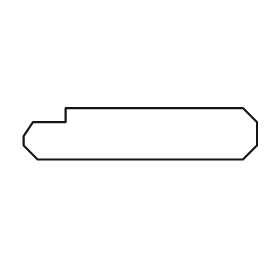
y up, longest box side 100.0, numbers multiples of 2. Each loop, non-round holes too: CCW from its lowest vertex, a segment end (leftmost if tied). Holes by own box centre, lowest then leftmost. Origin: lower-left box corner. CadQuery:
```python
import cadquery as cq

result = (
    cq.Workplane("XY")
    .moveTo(6.0, 0.0)
    .lineTo(94.0, 0.0)
    .lineTo(100.0, 6.0)
    .lineTo(100.0, 16.0)
    .lineTo(94.0, 22.0)
    .lineTo(18.0, 22.0)
    .lineTo(18.0, 16.0)
    .lineTo(4.0, 16.0)
    .lineTo(0.0, 10.0)
    .lineTo(0.0, 6.0)
    .close()
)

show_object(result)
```